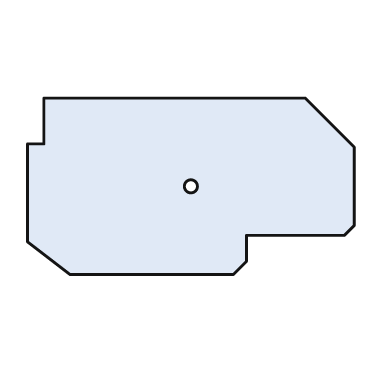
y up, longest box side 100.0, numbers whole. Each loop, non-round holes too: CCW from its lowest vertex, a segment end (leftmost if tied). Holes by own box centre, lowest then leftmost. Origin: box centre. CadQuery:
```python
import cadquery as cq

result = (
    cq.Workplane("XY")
    .moveTo(-37.0, -27.0)
    .lineTo(13.0, -27.0)
    .lineTo(17.0, -23.0)
    .lineTo(17.0, -15.0)
    .lineTo(47.0, -15.0)
    .lineTo(50.0, -12.0)
    .lineTo(50.0, 12.0)
    .lineTo(35.0, 27.0)
    .lineTo(-45.0, 27.0)
    .lineTo(-45.0, 13.0)
    .lineTo(-50.0, 13.0)
    .lineTo(-50.0, -17.0)
    .close()
    .moveTo(0.0, 0.0)
    .circle(2.0)
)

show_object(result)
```